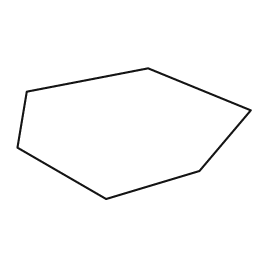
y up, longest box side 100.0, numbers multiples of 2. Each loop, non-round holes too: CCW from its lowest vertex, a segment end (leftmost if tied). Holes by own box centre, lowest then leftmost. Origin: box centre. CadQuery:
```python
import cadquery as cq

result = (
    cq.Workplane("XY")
    .moveTo(-12.0, -28.0)
    .lineTo(28.0, -16.0)
    .lineTo(50.0, 10.0)
    .lineTo(6.0, 28.0)
    .lineTo(-46.0, 18.0)
    .lineTo(-50.0, -6.0)
    .close()
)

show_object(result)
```